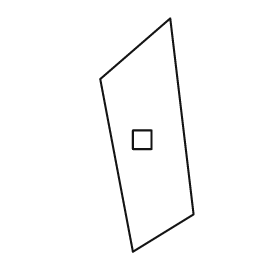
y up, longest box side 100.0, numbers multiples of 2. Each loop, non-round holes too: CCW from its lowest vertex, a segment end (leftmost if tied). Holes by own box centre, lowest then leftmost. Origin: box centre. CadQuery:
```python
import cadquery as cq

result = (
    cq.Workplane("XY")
    .moveTo(-6.0, -50.0)
    .lineTo(20.0, -34.0)
    .lineTo(10.0, 50.0)
    .lineTo(-20.0, 24.0)
    .close()
    .moveTo(-6.0, -6.0)
    .lineTo(2.0, -6.0)
    .lineTo(2.0, 2.0)
    .lineTo(-6.0, 2.0)
    .close()
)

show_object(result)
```